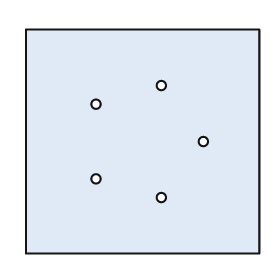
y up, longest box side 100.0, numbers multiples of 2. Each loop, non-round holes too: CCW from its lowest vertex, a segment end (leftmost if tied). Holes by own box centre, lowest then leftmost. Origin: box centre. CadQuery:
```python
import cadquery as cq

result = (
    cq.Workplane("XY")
    .moveTo(-50.0, -48.0)
    .lineTo(50.0, -48.0)
    .lineTo(50.0, 48.0)
    .lineTo(-50.0, 48.0)
    .close()
    .moveTo(8.0, -24.0)
    .circle(2.0)
    .moveTo(-20.0, -16.0)
    .circle(2.0)
    .moveTo(26.0, 0.0)
    .circle(2.0)
    .moveTo(-20.0, 16.0)
    .circle(2.0)
    .moveTo(8.0, 24.0)
    .circle(2.0)
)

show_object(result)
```